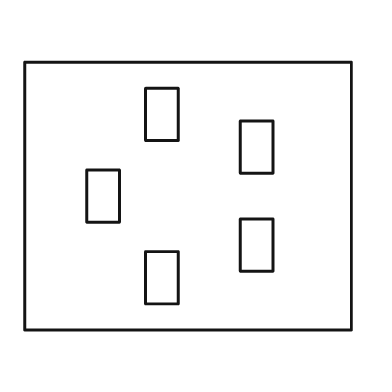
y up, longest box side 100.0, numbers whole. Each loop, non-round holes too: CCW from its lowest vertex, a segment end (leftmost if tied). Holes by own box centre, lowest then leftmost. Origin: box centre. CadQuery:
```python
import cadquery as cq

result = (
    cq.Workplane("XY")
    .moveTo(-50.0, -41.0)
    .lineTo(50.0, -41.0)
    .lineTo(50.0, 41.0)
    .lineTo(-50.0, 41.0)
    .close()
    .moveTo(-13.0, -33.0)
    .lineTo(-3.0, -33.0)
    .lineTo(-3.0, -17.0)
    .lineTo(-13.0, -17.0)
    .close()
    .moveTo(16.0, -23.0)
    .lineTo(26.0, -23.0)
    .lineTo(26.0, -7.0)
    .lineTo(16.0, -7.0)
    .close()
    .moveTo(-31.0, -8.0)
    .lineTo(-21.0, -8.0)
    .lineTo(-21.0, 8.0)
    .lineTo(-31.0, 8.0)
    .close()
    .moveTo(16.0, 7.0)
    .lineTo(26.0, 7.0)
    .lineTo(26.0, 23.0)
    .lineTo(16.0, 23.0)
    .close()
    .moveTo(-13.0, 17.0)
    .lineTo(-3.0, 17.0)
    .lineTo(-3.0, 33.0)
    .lineTo(-13.0, 33.0)
    .close()
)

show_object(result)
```